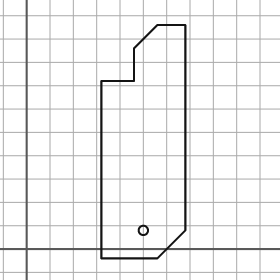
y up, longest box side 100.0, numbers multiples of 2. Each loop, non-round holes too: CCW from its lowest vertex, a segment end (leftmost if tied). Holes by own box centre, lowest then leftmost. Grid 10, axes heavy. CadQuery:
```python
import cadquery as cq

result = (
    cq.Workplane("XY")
    .moveTo(32.0, -4.0)
    .lineTo(56.0, -4.0)
    .lineTo(68.0, 8.0)
    .lineTo(68.0, 96.0)
    .lineTo(56.0, 96.0)
    .lineTo(46.0, 86.0)
    .lineTo(46.0, 72.0)
    .lineTo(32.0, 72.0)
    .close()
    .moveTo(50.0, 8.0)
    .circle(2.0)
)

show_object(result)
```